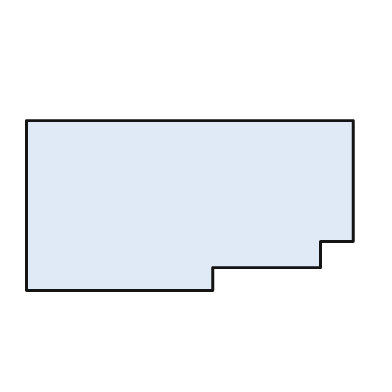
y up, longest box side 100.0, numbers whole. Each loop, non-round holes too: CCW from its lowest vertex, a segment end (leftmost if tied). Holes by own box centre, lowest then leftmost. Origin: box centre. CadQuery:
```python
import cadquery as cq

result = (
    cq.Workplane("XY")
    .moveTo(-50.0, -26.0)
    .lineTo(7.0, -26.0)
    .lineTo(7.0, -19.0)
    .lineTo(40.0, -19.0)
    .lineTo(40.0, -11.0)
    .lineTo(50.0, -11.0)
    .lineTo(50.0, 26.0)
    .lineTo(-50.0, 26.0)
    .close()
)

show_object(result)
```